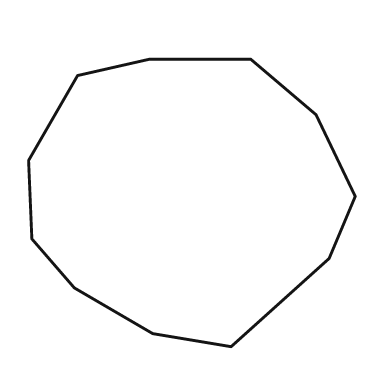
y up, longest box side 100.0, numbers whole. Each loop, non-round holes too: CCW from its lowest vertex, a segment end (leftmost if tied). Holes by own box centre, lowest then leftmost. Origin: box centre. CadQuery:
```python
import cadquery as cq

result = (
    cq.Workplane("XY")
    .moveTo(12.0, -44.0)
    .lineTo(42.0, -17.0)
    .lineTo(50.0, 2.0)
    .lineTo(38.0, 27.0)
    .lineTo(18.0, 44.0)
    .lineTo(-13.0, 44.0)
    .lineTo(-35.0, 39.0)
    .lineTo(-50.0, 13.0)
    .lineTo(-49.0, -11.0)
    .lineTo(-36.0, -26.0)
    .lineTo(-12.0, -40.0)
    .close()
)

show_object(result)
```